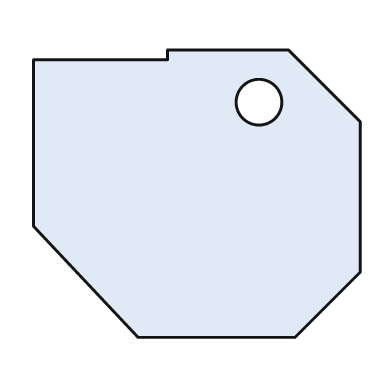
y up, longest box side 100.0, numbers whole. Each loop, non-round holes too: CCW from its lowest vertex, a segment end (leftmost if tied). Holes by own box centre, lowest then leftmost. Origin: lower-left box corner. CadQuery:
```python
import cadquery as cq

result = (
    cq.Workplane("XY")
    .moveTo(32.0, 0.0)
    .lineTo(80.0, 0.0)
    .lineTo(100.0, 20.0)
    .lineTo(100.0, 66.0)
    .lineTo(78.0, 88.0)
    .lineTo(41.0, 88.0)
    .lineTo(41.0, 85.0)
    .lineTo(0.0, 85.0)
    .lineTo(0.0, 34.0)
    .close()
    .moveTo(69.0, 72.0)
    .circle(7.0)
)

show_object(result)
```